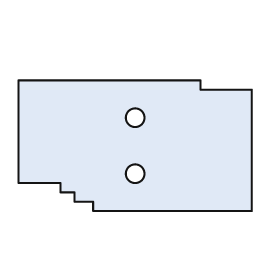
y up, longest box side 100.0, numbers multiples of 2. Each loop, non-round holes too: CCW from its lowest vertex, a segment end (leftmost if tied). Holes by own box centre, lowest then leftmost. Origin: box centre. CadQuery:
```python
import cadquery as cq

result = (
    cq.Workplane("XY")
    .moveTo(-18.0, -28.0)
    .lineTo(50.0, -28.0)
    .lineTo(50.0, 24.0)
    .lineTo(28.0, 24.0)
    .lineTo(28.0, 28.0)
    .lineTo(-50.0, 28.0)
    .lineTo(-50.0, -16.0)
    .lineTo(-32.0, -16.0)
    .lineTo(-32.0, -20.0)
    .lineTo(-26.0, -20.0)
    .lineTo(-26.0, -24.0)
    .lineTo(-18.0, -24.0)
    .close()
    .moveTo(0.0, -12.0)
    .circle(4.0)
    .moveTo(0.0, 12.0)
    .circle(4.0)
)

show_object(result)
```